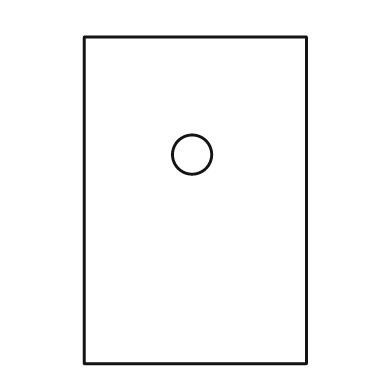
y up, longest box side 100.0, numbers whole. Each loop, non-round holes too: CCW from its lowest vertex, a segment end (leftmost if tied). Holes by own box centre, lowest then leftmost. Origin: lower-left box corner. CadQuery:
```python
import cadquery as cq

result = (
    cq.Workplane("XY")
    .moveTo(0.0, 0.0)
    .lineTo(68.0, 0.0)
    .lineTo(68.0, 100.0)
    .lineTo(0.0, 100.0)
    .close()
    .moveTo(33.0, 64.0)
    .circle(6.0)
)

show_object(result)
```